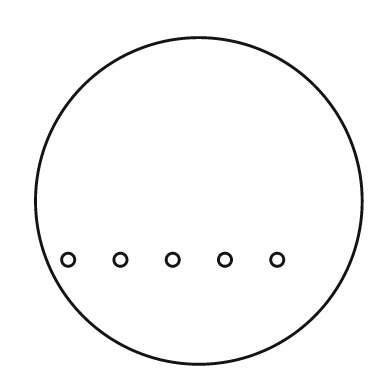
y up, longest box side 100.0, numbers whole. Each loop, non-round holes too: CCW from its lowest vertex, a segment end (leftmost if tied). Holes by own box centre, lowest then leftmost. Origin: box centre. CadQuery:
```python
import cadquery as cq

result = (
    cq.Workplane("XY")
    .moveTo(0.0, 0.0)
    .circle(50.0)
    .moveTo(-40.0, -18.0)
    .circle(2.0)
    .moveTo(-24.0, -18.0)
    .circle(2.0)
    .moveTo(-8.0, -18.0)
    .circle(2.0)
    .moveTo(8.0, -18.0)
    .circle(2.0)
    .moveTo(24.0, -18.0)
    .circle(2.0)
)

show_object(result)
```